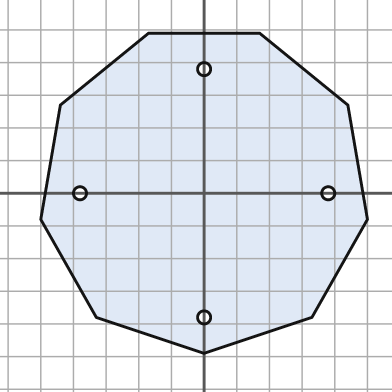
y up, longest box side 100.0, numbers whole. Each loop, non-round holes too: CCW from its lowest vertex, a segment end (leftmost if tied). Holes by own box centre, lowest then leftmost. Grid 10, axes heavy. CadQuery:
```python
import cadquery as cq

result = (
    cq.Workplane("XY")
    .moveTo(0.0, -49.0)
    .lineTo(33.0, -38.0)
    .lineTo(50.0, -8.0)
    .lineTo(44.0, 27.0)
    .lineTo(17.0, 49.0)
    .lineTo(-17.0, 49.0)
    .lineTo(-44.0, 27.0)
    .lineTo(-50.0, -8.0)
    .lineTo(-33.0, -38.0)
    .close()
    .moveTo(0.0, -38.0)
    .circle(2.0)
    .moveTo(-38.0, 0.0)
    .circle(2.0)
    .moveTo(38.0, 0.0)
    .circle(2.0)
    .moveTo(0.0, 38.0)
    .circle(2.0)
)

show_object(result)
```